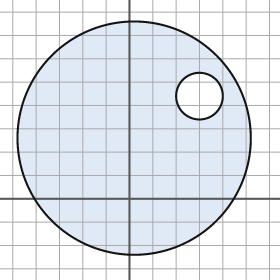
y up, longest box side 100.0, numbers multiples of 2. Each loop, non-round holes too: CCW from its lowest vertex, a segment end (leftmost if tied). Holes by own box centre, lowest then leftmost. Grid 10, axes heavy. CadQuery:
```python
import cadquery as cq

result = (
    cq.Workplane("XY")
    .moveTo(2.0, 26.0)
    .circle(50.0)
    .moveTo(30.0, 44.0)
    .circle(10.0)
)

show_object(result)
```